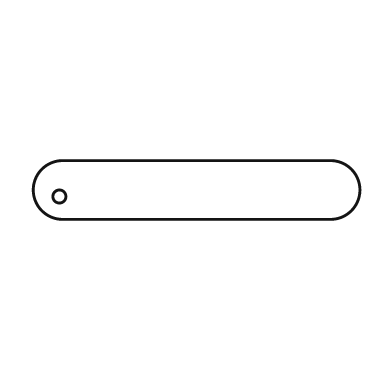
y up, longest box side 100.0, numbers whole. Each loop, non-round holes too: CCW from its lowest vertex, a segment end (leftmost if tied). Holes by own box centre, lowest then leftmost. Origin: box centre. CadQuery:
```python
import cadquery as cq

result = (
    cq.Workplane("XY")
    .moveTo(-41.0, -9.0)
    .lineTo(41.0, -9.0)
    .threePointArc((50.0, 0.0), (41.0, 9.0))
    .lineTo(-41.0, 9.0)
    .threePointArc((-50.0, 0.0), (-41.0, -9.0))
    .close()
    .moveTo(-42.0, -2.0)
    .circle(2.0)
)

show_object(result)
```